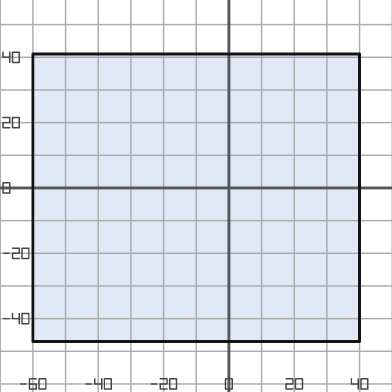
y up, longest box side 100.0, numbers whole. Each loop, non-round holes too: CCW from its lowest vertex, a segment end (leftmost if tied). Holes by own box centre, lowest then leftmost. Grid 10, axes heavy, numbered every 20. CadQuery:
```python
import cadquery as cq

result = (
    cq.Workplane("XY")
    .moveTo(-60.0, -47.0)
    .lineTo(40.0, -47.0)
    .lineTo(40.0, 41.0)
    .lineTo(-60.0, 41.0)
    .close()
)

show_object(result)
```